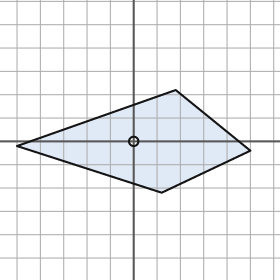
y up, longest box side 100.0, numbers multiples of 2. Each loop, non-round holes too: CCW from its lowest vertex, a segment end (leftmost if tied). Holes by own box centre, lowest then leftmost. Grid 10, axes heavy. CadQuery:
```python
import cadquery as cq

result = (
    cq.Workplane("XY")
    .moveTo(12.0, -22.0)
    .lineTo(50.0, -4.0)
    .lineTo(18.0, 22.0)
    .lineTo(-50.0, -2.0)
    .close()
    .moveTo(0.0, 0.0)
    .circle(2.0)
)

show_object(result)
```